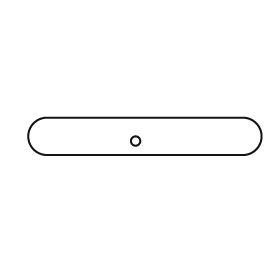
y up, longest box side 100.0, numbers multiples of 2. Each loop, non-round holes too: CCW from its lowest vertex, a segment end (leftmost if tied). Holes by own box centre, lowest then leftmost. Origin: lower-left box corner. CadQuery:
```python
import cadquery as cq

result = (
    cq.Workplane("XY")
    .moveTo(8.0, 0.0)
    .lineTo(92.0, 0.0)
    .threePointArc((100.0, 8.0), (92.0, 16.0))
    .lineTo(8.0, 16.0)
    .threePointArc((0.0, 8.0), (8.0, 0.0))
    .close()
    .moveTo(46.0, 6.0)
    .circle(2.0)
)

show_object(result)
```